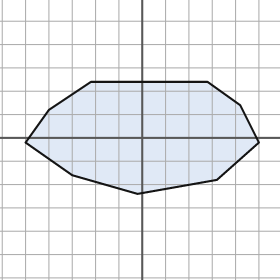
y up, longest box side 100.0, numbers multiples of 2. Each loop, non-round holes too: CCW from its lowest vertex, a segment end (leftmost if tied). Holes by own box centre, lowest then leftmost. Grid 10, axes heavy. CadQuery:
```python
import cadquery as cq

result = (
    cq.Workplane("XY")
    .moveTo(-2.0, -24.0)
    .lineTo(32.0, -18.0)
    .lineTo(50.0, -2.0)
    .lineTo(42.0, 14.0)
    .lineTo(28.0, 24.0)
    .lineTo(-22.0, 24.0)
    .lineTo(-40.0, 12.0)
    .lineTo(-50.0, -2.0)
    .lineTo(-30.0, -16.0)
    .close()
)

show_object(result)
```